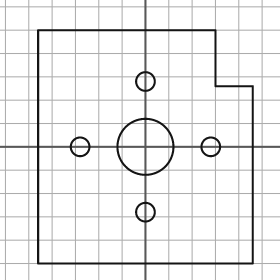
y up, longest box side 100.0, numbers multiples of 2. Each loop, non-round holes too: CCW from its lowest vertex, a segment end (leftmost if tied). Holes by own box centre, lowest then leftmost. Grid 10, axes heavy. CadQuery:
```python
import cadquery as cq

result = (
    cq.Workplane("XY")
    .moveTo(-46.0, -50.0)
    .lineTo(46.0, -50.0)
    .lineTo(46.0, 26.0)
    .lineTo(30.0, 26.0)
    .lineTo(30.0, 50.0)
    .lineTo(-46.0, 50.0)
    .close()
    .moveTo(0.0, -28.0)
    .circle(4.0)
    .moveTo(-28.0, 0.0)
    .circle(4.0)
    .moveTo(0.0, 0.0)
    .circle(12.0)
    .moveTo(28.0, 0.0)
    .circle(4.0)
    .moveTo(0.0, 28.0)
    .circle(4.0)
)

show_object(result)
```